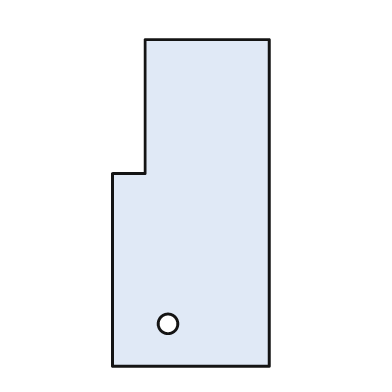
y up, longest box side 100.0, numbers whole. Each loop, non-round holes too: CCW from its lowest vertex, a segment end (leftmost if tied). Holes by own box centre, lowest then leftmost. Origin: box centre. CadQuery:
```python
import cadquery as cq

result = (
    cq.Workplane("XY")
    .moveTo(-24.0, -50.0)
    .lineTo(24.0, -50.0)
    .lineTo(24.0, 50.0)
    .lineTo(-14.0, 50.0)
    .lineTo(-14.0, 9.0)
    .lineTo(-24.0, 9.0)
    .close()
    .moveTo(-7.0, -37.0)
    .circle(3.0)
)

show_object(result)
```